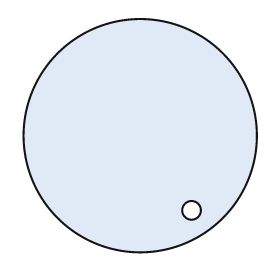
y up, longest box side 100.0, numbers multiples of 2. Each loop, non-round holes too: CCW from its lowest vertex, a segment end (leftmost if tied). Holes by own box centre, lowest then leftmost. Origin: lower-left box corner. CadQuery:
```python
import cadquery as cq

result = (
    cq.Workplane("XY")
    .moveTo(50.0, 50.0)
    .circle(50.0)
    .moveTo(72.0, 18.0)
    .circle(4.0)
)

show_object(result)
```